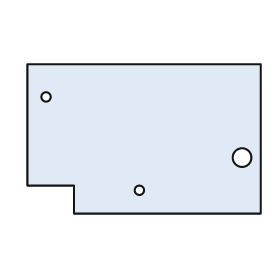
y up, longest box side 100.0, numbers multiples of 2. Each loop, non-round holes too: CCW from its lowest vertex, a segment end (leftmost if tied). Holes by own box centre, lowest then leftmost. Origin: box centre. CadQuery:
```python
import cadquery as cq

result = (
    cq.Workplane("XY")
    .moveTo(-30.0, -32.0)
    .lineTo(50.0, -32.0)
    .lineTo(50.0, 32.0)
    .lineTo(-50.0, 32.0)
    .lineTo(-50.0, -20.0)
    .lineTo(-30.0, -20.0)
    .close()
    .moveTo(-2.0, -22.0)
    .circle(2.0)
    .moveTo(42.0, -8.0)
    .circle(4.0)
    .moveTo(-42.0, 18.0)
    .circle(2.0)
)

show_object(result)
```